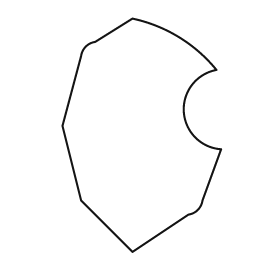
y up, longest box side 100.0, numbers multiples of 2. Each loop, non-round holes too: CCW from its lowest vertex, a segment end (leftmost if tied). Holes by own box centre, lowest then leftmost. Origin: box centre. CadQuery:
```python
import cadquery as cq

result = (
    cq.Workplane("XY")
    .moveTo(-4.0, -50.0)
    .lineTo(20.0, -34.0)
    .threePointArc((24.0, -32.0), (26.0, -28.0))
    .lineTo(34.0, -6.0)
    .threePointArc((18.0, 10.0), (32.0, 28.0))
    .threePointArc((16.0, 42.0), (-4.0, 50.0))
    .lineTo(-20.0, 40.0)
    .threePointArc((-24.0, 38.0), (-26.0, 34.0))
    .lineTo(-34.0, 4.0)
    .lineTo(-26.0, -28.0)
    .close()
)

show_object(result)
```